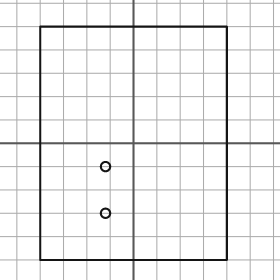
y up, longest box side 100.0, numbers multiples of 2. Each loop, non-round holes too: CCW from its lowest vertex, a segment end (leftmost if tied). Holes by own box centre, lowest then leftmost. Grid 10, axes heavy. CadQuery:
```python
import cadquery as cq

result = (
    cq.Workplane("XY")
    .moveTo(-40.0, -50.0)
    .lineTo(40.0, -50.0)
    .lineTo(40.0, 50.0)
    .lineTo(-40.0, 50.0)
    .close()
    .moveTo(-12.0, -30.0)
    .circle(2.0)
    .moveTo(-12.0, -10.0)
    .circle(2.0)
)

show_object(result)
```